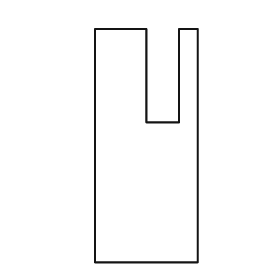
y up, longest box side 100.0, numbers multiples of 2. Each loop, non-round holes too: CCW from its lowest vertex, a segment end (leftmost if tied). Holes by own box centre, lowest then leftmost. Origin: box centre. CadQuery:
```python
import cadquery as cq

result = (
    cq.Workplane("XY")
    .moveTo(-22.0, -50.0)
    .lineTo(22.0, -50.0)
    .lineTo(22.0, 50.0)
    .lineTo(14.0, 50.0)
    .lineTo(14.0, 10.0)
    .lineTo(0.0, 10.0)
    .lineTo(0.0, 50.0)
    .lineTo(-22.0, 50.0)
    .close()
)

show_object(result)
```